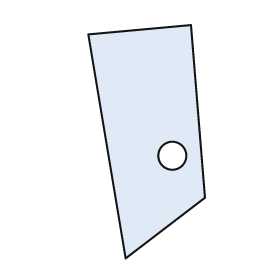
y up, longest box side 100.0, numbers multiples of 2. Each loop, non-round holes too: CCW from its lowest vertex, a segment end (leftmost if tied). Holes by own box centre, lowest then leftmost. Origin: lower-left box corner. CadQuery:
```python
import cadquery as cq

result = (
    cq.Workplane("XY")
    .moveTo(16.0, 0.0)
    .lineTo(50.0, 26.0)
    .lineTo(44.0, 100.0)
    .lineTo(0.0, 96.0)
    .close()
    .moveTo(36.0, 44.0)
    .circle(6.0)
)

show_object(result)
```